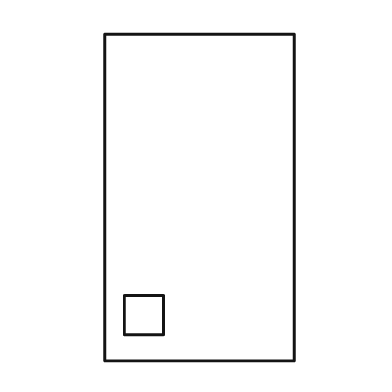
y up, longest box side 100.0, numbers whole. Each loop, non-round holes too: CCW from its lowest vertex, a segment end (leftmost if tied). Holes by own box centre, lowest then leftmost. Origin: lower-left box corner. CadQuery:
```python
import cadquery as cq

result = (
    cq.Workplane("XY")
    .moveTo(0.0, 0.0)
    .lineTo(58.0, 0.0)
    .lineTo(58.0, 100.0)
    .lineTo(0.0, 100.0)
    .close()
    .moveTo(6.0, 8.0)
    .lineTo(18.0, 8.0)
    .lineTo(18.0, 20.0)
    .lineTo(6.0, 20.0)
    .close()
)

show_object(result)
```